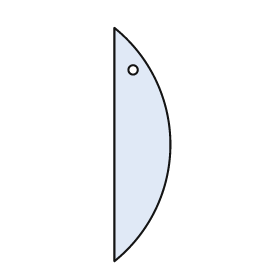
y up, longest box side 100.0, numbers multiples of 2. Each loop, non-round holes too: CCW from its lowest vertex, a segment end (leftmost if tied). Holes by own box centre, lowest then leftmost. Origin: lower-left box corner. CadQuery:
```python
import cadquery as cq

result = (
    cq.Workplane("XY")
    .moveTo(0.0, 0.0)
    .threePointArc((24.0, 50.0), (0.0, 100.0))
    .close()
    .moveTo(8.0, 82.0)
    .circle(2.0)
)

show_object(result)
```